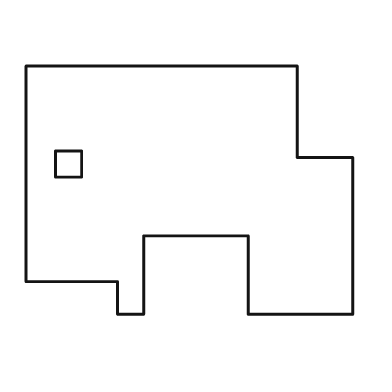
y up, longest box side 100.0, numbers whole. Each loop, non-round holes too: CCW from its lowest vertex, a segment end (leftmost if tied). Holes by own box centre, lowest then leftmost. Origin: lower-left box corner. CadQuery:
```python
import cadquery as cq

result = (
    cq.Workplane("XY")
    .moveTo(28.0, 0.0)
    .lineTo(36.0, 0.0)
    .lineTo(36.0, 24.0)
    .lineTo(68.0, 24.0)
    .lineTo(68.0, 0.0)
    .lineTo(100.0, 0.0)
    .lineTo(100.0, 48.0)
    .lineTo(83.0, 48.0)
    .lineTo(83.0, 76.0)
    .lineTo(0.0, 76.0)
    .lineTo(0.0, 10.0)
    .lineTo(28.0, 10.0)
    .close()
    .moveTo(9.0, 42.0)
    .lineTo(17.0, 42.0)
    .lineTo(17.0, 50.0)
    .lineTo(9.0, 50.0)
    .close()
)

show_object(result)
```